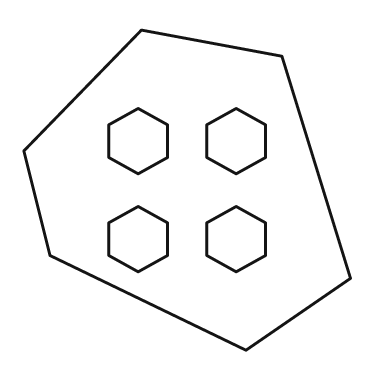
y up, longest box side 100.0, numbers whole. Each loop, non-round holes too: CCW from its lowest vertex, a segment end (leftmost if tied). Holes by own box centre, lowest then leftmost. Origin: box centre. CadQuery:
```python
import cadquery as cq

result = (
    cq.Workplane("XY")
    .moveTo(18.0, -49.0)
    .lineTo(50.0, -27.0)
    .lineTo(29.0, 41.0)
    .lineTo(-14.0, 49.0)
    .lineTo(-50.0, 12.0)
    .lineTo(-42.0, -20.0)
    .close()
    .moveTo(-15.0, -25.0)
    .lineTo(-6.0, -20.0)
    .lineTo(-6.0, -10.0)
    .lineTo(-15.0, -5.0)
    .lineTo(-24.0, -10.0)
    .lineTo(-24.0, -20.0)
    .close()
    .moveTo(15.0, -25.0)
    .lineTo(24.0, -20.0)
    .lineTo(24.0, -10.0)
    .lineTo(15.0, -5.0)
    .lineTo(6.0, -10.0)
    .lineTo(6.0, -20.0)
    .close()
    .moveTo(-15.0, 5.0)
    .lineTo(-6.0, 10.0)
    .lineTo(-6.0, 20.0)
    .lineTo(-15.0, 25.0)
    .lineTo(-24.0, 20.0)
    .lineTo(-24.0, 10.0)
    .close()
    .moveTo(15.0, 5.0)
    .lineTo(24.0, 10.0)
    .lineTo(24.0, 20.0)
    .lineTo(15.0, 25.0)
    .lineTo(6.0, 20.0)
    .lineTo(6.0, 10.0)
    .close()
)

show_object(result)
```